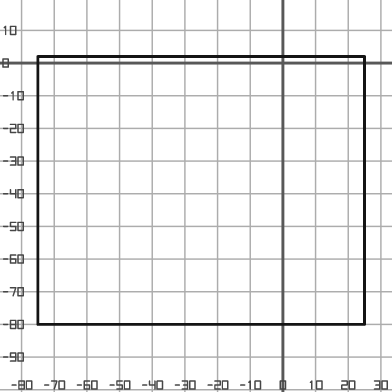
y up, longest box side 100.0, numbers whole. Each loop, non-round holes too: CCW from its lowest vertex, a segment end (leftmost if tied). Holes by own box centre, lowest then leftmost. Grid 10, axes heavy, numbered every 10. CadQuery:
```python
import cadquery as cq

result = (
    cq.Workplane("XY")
    .moveTo(-75.0, -80.0)
    .lineTo(25.0, -80.0)
    .lineTo(25.0, 2.0)
    .lineTo(-75.0, 2.0)
    .close()
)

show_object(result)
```